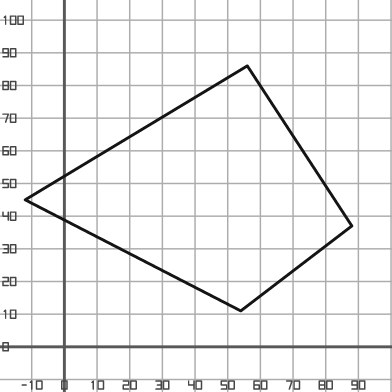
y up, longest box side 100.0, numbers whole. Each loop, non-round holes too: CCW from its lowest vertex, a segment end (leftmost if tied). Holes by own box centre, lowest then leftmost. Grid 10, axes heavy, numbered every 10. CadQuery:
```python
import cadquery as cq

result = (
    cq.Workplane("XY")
    .moveTo(54.0, 11.0)
    .lineTo(88.0, 37.0)
    .lineTo(56.0, 86.0)
    .lineTo(-12.0, 45.0)
    .close()
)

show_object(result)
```